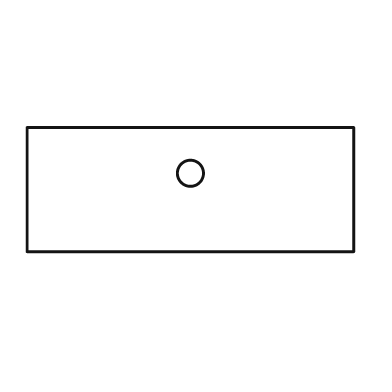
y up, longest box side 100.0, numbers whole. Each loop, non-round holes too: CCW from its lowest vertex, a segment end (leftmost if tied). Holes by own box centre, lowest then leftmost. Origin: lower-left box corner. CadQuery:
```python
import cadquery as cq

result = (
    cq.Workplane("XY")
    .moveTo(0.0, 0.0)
    .lineTo(100.0, 0.0)
    .lineTo(100.0, 38.0)
    .lineTo(0.0, 38.0)
    .close()
    .moveTo(50.0, 24.0)
    .circle(4.0)
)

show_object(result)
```